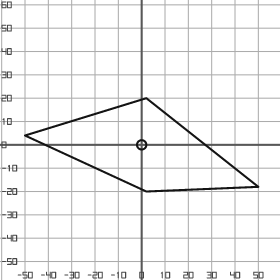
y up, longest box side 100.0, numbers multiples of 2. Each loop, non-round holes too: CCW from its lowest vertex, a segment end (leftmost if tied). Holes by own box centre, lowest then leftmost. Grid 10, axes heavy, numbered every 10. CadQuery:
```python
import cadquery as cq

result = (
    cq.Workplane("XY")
    .moveTo(2.0, -20.0)
    .lineTo(50.0, -18.0)
    .lineTo(2.0, 20.0)
    .lineTo(-50.0, 4.0)
    .close()
    .moveTo(0.0, 0.0)
    .circle(2.0)
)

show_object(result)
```